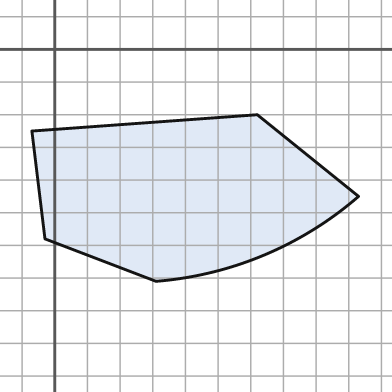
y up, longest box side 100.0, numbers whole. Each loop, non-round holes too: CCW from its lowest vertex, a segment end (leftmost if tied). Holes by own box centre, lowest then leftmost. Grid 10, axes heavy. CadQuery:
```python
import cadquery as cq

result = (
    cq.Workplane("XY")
    .moveTo(31.0, -71.0)
    .threePointArc((64.0, -63.0), (93.0, -45.0))
    .lineTo(62.0, -20.0)
    .lineTo(-7.0, -25.0)
    .lineTo(-3.0, -58.0)
    .close()
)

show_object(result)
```